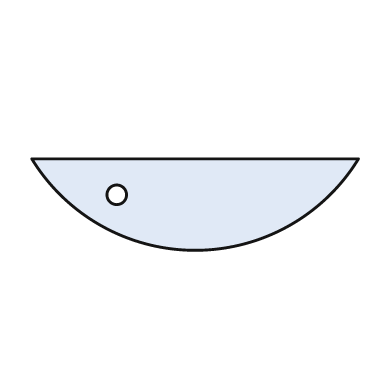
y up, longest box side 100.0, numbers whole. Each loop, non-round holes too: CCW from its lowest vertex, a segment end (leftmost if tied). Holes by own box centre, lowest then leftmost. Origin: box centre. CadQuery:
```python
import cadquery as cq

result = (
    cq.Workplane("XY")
    .moveTo(-50.0, 14.0)
    .threePointArc((0.0, -14.0), (50.0, 14.0))
    .close()
    .moveTo(-24.0, 3.0)
    .circle(3.0)
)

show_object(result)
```